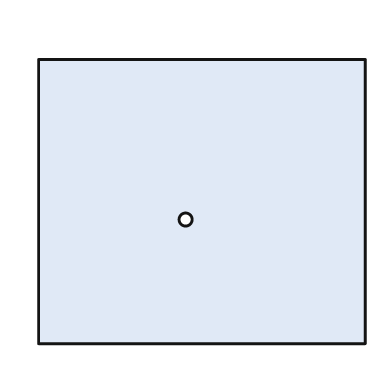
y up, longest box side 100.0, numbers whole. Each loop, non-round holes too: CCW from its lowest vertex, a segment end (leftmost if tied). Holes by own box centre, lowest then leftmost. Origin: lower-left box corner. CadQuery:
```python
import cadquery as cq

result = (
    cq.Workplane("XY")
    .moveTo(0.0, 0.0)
    .lineTo(100.0, 0.0)
    .lineTo(100.0, 87.0)
    .lineTo(0.0, 87.0)
    .close()
    .moveTo(45.0, 38.0)
    .circle(2.0)
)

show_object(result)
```